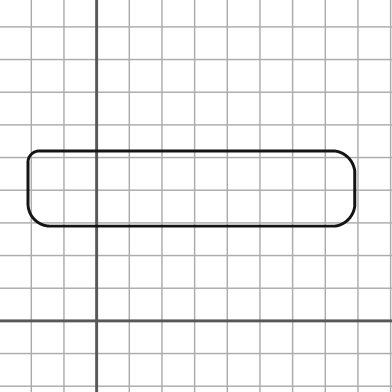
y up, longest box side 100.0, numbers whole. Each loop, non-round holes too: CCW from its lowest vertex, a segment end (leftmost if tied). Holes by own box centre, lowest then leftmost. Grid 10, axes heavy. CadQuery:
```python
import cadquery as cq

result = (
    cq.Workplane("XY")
    .moveTo(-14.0, 29.0)
    .lineTo(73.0, 29.0)
    .threePointArc((77.0, 31.0), (79.0, 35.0))
    .lineTo(79.0, 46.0)
    .threePointArc((77.0, 50.0), (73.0, 52.0))
    .lineTo(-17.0, 52.0)
    .threePointArc((-20.0, 51.0), (-21.0, 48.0))
    .lineTo(-21.0, 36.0)
    .threePointArc((-19.0, 31.0), (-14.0, 29.0))
    .close()
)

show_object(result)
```